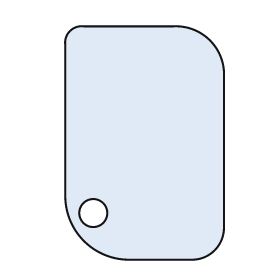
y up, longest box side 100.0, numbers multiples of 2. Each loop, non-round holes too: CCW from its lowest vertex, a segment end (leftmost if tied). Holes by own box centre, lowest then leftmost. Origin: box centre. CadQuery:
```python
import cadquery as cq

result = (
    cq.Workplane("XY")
    .moveTo(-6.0, -50.0)
    .lineTo(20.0, -50.0)
    .threePointArc((30.0, -46.0), (34.0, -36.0))
    .lineTo(34.0, 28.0)
    .threePointArc((28.0, 44.0), (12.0, 50.0))
    .lineTo(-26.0, 50.0)
    .threePointArc((-32.0, 48.0), (-34.0, 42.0))
    .lineTo(-34.0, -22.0)
    .threePointArc((-26.0, -42.0), (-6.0, -50.0))
    .close()
    .moveTo(-22.0, -30.0)
    .circle(6.0)
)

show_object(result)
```